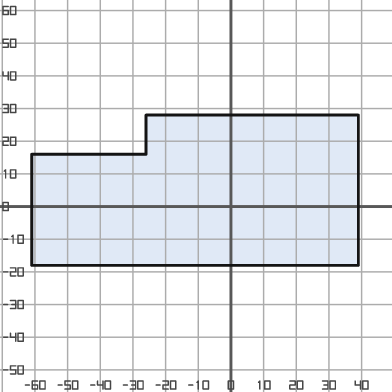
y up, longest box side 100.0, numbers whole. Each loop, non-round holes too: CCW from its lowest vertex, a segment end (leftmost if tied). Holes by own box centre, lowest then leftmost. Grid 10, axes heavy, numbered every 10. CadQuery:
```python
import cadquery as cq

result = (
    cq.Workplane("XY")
    .moveTo(-61.0, -18.0)
    .lineTo(39.0, -18.0)
    .lineTo(39.0, 28.0)
    .lineTo(-26.0, 28.0)
    .lineTo(-26.0, 16.0)
    .lineTo(-61.0, 16.0)
    .close()
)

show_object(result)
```